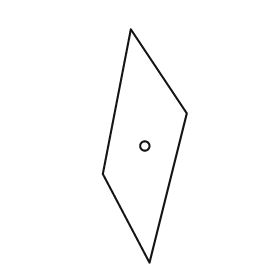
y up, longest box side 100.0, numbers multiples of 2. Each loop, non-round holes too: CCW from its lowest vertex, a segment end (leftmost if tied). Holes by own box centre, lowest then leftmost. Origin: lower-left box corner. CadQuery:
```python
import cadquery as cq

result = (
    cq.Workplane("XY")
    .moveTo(20.0, 0.0)
    .lineTo(36.0, 64.0)
    .lineTo(12.0, 100.0)
    .lineTo(0.0, 38.0)
    .close()
    .moveTo(18.0, 50.0)
    .circle(2.0)
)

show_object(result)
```